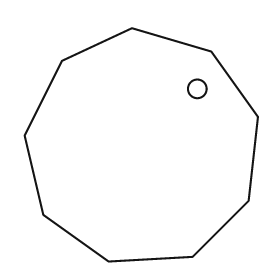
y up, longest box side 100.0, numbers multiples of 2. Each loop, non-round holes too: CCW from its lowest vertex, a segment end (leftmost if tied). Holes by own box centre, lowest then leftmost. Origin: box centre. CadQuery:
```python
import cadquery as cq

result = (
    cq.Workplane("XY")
    .moveTo(-14.0, -50.0)
    .lineTo(22.0, -48.0)
    .lineTo(46.0, -24.0)
    .lineTo(50.0, 12.0)
    .lineTo(30.0, 40.0)
    .lineTo(-4.0, 50.0)
    .lineTo(-34.0, 36.0)
    .lineTo(-50.0, 4.0)
    .lineTo(-42.0, -30.0)
    .close()
    .moveTo(24.0, 24.0)
    .circle(4.0)
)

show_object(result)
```